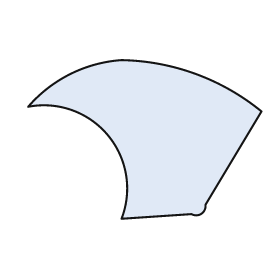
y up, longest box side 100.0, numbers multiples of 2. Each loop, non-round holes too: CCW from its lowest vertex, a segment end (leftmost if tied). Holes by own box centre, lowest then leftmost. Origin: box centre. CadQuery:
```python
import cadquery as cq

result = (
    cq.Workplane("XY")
    .moveTo(-10.0, -34.0)
    .lineTo(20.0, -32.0)
    .threePointArc((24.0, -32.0), (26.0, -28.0))
    .lineTo(50.0, 12.0)
    .threePointArc((22.0, 28.0), (-10.0, 34.0))
    .threePointArc((-32.0, 28.0), (-50.0, 14.0))
    .threePointArc((-16.0, 2.0), (-10.0, -34.0))
    .close()
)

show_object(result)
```